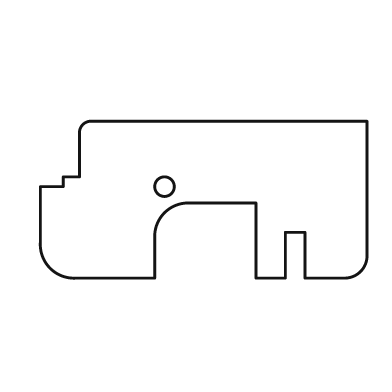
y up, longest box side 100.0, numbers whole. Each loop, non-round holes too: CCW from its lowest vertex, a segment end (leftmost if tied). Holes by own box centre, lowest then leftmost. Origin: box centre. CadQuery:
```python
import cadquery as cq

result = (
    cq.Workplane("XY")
    .moveTo(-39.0, -24.0)
    .lineTo(-15.0, -24.0)
    .lineTo(-15.0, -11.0)
    .threePointArc((-12.0, -4.0), (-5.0, -1.0))
    .lineTo(16.0, -1.0)
    .lineTo(16.0, -24.0)
    .lineTo(25.0, -24.0)
    .lineTo(25.0, -10.0)
    .lineTo(31.0, -10.0)
    .lineTo(31.0, -24.0)
    .lineTo(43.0, -24.0)
    .threePointArc((48.0, -22.0), (50.0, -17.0))
    .lineTo(50.0, 24.0)
    .lineTo(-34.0, 24.0)
    .threePointArc((-37.0, 23.0), (-38.0, 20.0))
    .lineTo(-38.0, 7.0)
    .lineTo(-43.0, 7.0)
    .lineTo(-43.0, 4.0)
    .lineTo(-50.0, 4.0)
    .lineTo(-50.0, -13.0)
    .threePointArc((-47.0, -21.0), (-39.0, -24.0))
    .close()
    .moveTo(-12.0, 4.0)
    .circle(3.0)
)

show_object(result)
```